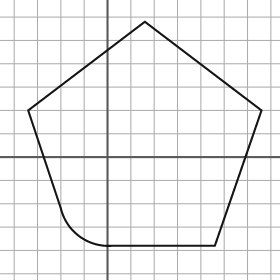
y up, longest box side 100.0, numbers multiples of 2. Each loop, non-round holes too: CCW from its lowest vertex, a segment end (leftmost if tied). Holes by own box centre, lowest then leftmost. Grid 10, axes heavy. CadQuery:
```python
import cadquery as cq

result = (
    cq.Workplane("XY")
    .moveTo(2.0, -38.0)
    .lineTo(46.0, -38.0)
    .lineTo(66.0, 20.0)
    .lineTo(16.0, 58.0)
    .lineTo(-34.0, 20.0)
    .lineTo(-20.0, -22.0)
    .threePointArc((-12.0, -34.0), (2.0, -38.0))
    .close()
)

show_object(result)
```